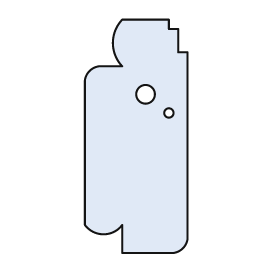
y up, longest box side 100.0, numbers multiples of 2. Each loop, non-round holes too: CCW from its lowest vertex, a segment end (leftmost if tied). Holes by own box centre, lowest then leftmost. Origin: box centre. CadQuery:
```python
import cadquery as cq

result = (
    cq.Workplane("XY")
    .moveTo(-6.0, -50.0)
    .lineTo(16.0, -50.0)
    .threePointArc((20.0, -48.0), (22.0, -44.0))
    .lineTo(22.0, 36.0)
    .lineTo(18.0, 36.0)
    .lineTo(18.0, 46.0)
    .lineTo(14.0, 46.0)
    .lineTo(14.0, 50.0)
    .lineTo(-6.0, 50.0)
    .threePointArc((-10.0, 40.0), (-6.0, 30.0))
    .lineTo(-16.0, 30.0)
    .threePointArc((-20.0, 28.0), (-22.0, 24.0))
    .lineTo(-22.0, -38.0)
    .threePointArc((-14.0, -42.0), (-6.0, -38.0))
    .close()
    .moveTo(14.0, 10.0)
    .circle(2.0)
    .moveTo(4.0, 18.0)
    .circle(4.0)
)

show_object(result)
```